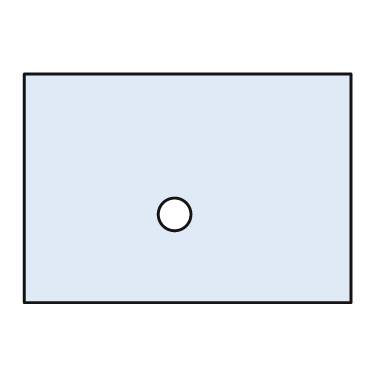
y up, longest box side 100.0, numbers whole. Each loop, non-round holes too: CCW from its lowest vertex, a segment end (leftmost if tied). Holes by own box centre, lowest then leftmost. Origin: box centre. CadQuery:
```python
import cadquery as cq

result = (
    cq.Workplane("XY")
    .moveTo(-50.0, -35.0)
    .lineTo(50.0, -35.0)
    .lineTo(50.0, 35.0)
    .lineTo(-50.0, 35.0)
    .close()
    .moveTo(-4.0, -8.0)
    .circle(5.0)
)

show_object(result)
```